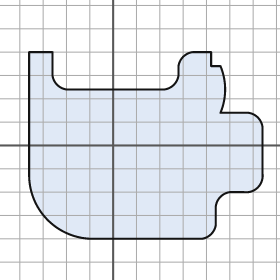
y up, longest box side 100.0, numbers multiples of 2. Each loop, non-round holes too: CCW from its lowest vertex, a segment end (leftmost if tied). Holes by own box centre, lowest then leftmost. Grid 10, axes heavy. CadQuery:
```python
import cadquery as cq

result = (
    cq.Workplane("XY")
    .moveTo(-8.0, -40.0)
    .lineTo(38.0, -40.0)
    .threePointArc((42.0, -38.0), (44.0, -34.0))
    .lineTo(44.0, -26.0)
    .threePointArc((46.0, -22.0), (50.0, -20.0))
    .lineTo(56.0, -20.0)
    .threePointArc((62.0, -18.0), (64.0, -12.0))
    .lineTo(64.0, 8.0)
    .threePointArc((62.0, 12.0), (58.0, 14.0))
    .lineTo(46.0, 14.0)
    .threePointArc((48.0, 24.0), (46.0, 34.0))
    .lineTo(42.0, 34.0)
    .lineTo(42.0, 40.0)
    .lineTo(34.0, 40.0)
    .threePointArc((30.0, 38.0), (28.0, 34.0))
    .lineTo(28.0, 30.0)
    .threePointArc((26.0, 26.0), (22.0, 24.0))
    .lineTo(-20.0, 24.0)
    .threePointArc((-24.0, 26.0), (-26.0, 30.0))
    .lineTo(-26.0, 40.0)
    .lineTo(-36.0, 40.0)
    .lineTo(-36.0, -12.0)
    .threePointArc((-28.0, -32.0), (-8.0, -40.0))
    .close()
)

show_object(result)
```